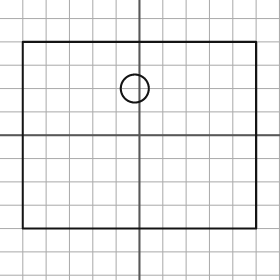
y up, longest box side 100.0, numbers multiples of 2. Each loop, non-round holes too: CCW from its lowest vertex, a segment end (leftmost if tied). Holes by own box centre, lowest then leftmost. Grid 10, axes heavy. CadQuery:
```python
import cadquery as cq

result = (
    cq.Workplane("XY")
    .moveTo(-50.0, -40.0)
    .lineTo(50.0, -40.0)
    .lineTo(50.0, 40.0)
    .lineTo(-50.0, 40.0)
    .close()
    .moveTo(-2.0, 20.0)
    .circle(6.0)
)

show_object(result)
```